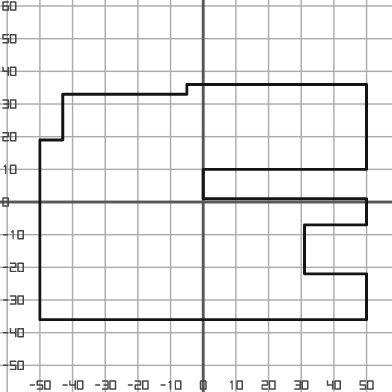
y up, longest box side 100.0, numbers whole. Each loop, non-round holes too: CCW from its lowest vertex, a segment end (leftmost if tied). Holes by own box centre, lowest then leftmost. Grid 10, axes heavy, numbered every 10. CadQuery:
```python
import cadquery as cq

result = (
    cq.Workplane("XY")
    .moveTo(-50.0, -36.0)
    .lineTo(50.0, -36.0)
    .lineTo(50.0, -22.0)
    .lineTo(31.0, -22.0)
    .lineTo(31.0, -7.0)
    .lineTo(50.0, -7.0)
    .lineTo(50.0, 1.0)
    .lineTo(0.0, 1.0)
    .lineTo(0.0, 10.0)
    .lineTo(50.0, 10.0)
    .lineTo(50.0, 36.0)
    .lineTo(-5.0, 36.0)
    .lineTo(-5.0, 33.0)
    .lineTo(-43.0, 33.0)
    .lineTo(-43.0, 19.0)
    .lineTo(-50.0, 19.0)
    .close()
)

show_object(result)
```